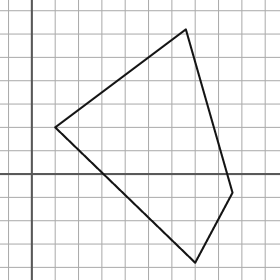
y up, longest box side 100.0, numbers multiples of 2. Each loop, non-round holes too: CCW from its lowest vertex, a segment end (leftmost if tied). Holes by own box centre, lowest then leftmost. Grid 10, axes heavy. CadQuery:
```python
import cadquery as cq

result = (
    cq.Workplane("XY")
    .moveTo(70.0, -38.0)
    .lineTo(86.0, -8.0)
    .lineTo(66.0, 62.0)
    .lineTo(10.0, 20.0)
    .close()
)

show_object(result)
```